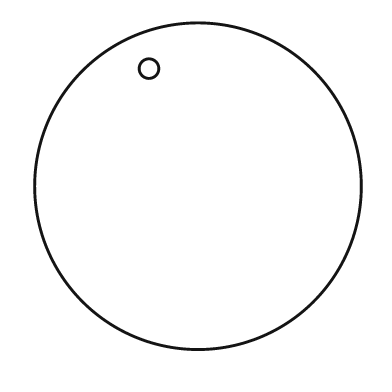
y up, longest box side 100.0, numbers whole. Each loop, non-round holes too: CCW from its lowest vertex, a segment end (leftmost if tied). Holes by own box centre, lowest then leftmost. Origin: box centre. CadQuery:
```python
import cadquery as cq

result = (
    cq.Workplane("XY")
    .moveTo(0.0, 0.0)
    .circle(50.0)
    .moveTo(-15.0, 36.0)
    .circle(3.0)
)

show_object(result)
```